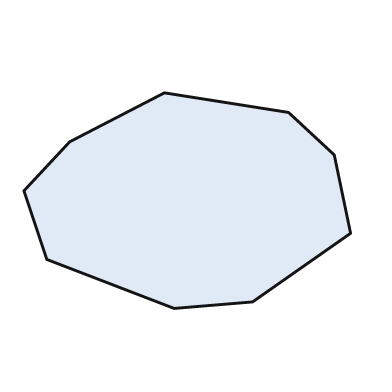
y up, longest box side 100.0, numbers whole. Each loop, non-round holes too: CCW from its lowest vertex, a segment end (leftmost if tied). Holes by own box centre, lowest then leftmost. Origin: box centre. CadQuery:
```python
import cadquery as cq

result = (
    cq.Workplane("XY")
    .moveTo(-4.0, -33.0)
    .lineTo(20.0, -31.0)
    .lineTo(50.0, -10.0)
    .lineTo(45.0, 14.0)
    .lineTo(31.0, 27.0)
    .lineTo(-7.0, 33.0)
    .lineTo(-36.0, 18.0)
    .lineTo(-50.0, 3.0)
    .lineTo(-43.0, -18.0)
    .close()
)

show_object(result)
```